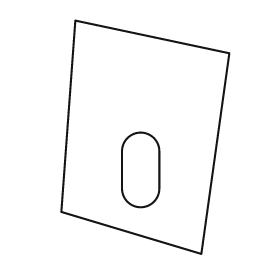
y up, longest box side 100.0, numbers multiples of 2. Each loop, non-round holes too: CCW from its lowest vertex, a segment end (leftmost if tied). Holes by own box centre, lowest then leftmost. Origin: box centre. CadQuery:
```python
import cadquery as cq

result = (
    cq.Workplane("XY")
    .moveTo(24.0, -50.0)
    .lineTo(36.0, 36.0)
    .lineTo(-30.0, 50.0)
    .lineTo(-36.0, -32.0)
    .close()
    .moveTo(-10.0, -22.0)
    .threePointArc((-2.0, -30.0), (6.0, -22.0))
    .lineTo(6.0, -6.0)
    .threePointArc((-2.0, 2.0), (-10.0, -6.0))
    .close()
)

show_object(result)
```